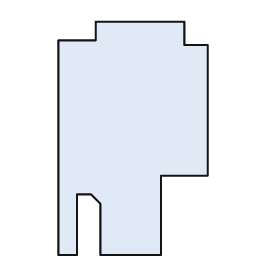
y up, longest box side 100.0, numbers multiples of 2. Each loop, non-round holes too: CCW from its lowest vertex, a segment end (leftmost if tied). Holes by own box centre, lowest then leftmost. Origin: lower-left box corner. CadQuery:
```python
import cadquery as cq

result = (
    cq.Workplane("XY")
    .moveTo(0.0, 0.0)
    .lineTo(8.0, 0.0)
    .lineTo(8.0, 26.0)
    .lineTo(14.0, 26.0)
    .lineTo(18.0, 22.0)
    .lineTo(18.0, 0.0)
    .lineTo(44.0, 0.0)
    .lineTo(44.0, 34.0)
    .lineTo(64.0, 34.0)
    .lineTo(64.0, 90.0)
    .lineTo(54.0, 90.0)
    .lineTo(54.0, 100.0)
    .lineTo(16.0, 100.0)
    .lineTo(16.0, 92.0)
    .lineTo(0.0, 92.0)
    .close()
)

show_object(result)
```